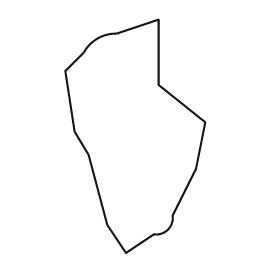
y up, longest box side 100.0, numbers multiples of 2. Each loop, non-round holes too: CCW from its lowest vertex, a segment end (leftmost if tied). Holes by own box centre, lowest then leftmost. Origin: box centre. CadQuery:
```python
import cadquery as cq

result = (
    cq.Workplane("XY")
    .moveTo(-4.0, -50.0)
    .lineTo(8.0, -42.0)
    .threePointArc((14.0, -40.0), (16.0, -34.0))
    .lineTo(26.0, -14.0)
    .lineTo(30.0, 6.0)
    .lineTo(10.0, 22.0)
    .lineTo(10.0, 50.0)
    .lineTo(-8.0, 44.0)
    .threePointArc((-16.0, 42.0), (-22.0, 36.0))
    .lineTo(-30.0, 28.0)
    .lineTo(-26.0, 2.0)
    .lineTo(-20.0, -8.0)
    .lineTo(-12.0, -38.0)
    .close()
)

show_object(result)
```